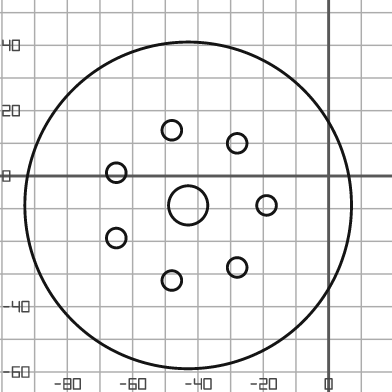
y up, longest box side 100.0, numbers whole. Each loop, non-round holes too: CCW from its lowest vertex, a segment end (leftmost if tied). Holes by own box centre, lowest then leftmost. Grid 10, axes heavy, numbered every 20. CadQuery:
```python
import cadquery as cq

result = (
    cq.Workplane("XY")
    .moveTo(-43.0, -9.0)
    .circle(50.0)
    .moveTo(-48.0, -32.0)
    .circle(3.0)
    .moveTo(-28.0, -28.0)
    .circle(3.0)
    .moveTo(-65.0, -19.0)
    .circle(3.0)
    .moveTo(-43.0, -9.0)
    .circle(6.0)
    .moveTo(-19.0, -9.0)
    .circle(3.0)
    .moveTo(-65.0, 1.0)
    .circle(3.0)
    .moveTo(-28.0, 10.0)
    .circle(3.0)
    .moveTo(-48.0, 14.0)
    .circle(3.0)
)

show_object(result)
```